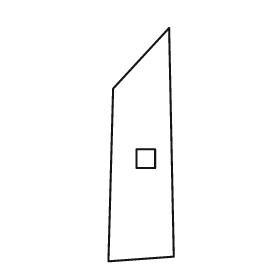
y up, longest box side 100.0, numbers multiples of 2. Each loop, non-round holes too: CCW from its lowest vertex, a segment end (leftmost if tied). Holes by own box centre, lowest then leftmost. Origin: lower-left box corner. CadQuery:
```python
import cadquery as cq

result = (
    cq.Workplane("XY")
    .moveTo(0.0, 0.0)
    .lineTo(28.0, 2.0)
    .lineTo(26.0, 100.0)
    .lineTo(2.0, 74.0)
    .close()
    .moveTo(12.0, 40.0)
    .lineTo(20.0, 40.0)
    .lineTo(20.0, 48.0)
    .lineTo(12.0, 48.0)
    .close()
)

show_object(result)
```